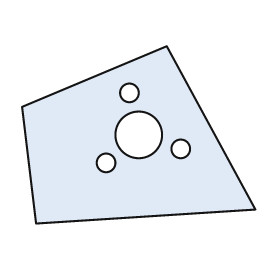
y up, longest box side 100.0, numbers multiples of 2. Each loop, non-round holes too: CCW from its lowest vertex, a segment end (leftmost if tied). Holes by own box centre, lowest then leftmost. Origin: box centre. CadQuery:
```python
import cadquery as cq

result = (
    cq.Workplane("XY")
    .moveTo(-44.0, -38.0)
    .lineTo(50.0, -32.0)
    .lineTo(12.0, 38.0)
    .lineTo(-50.0, 12.0)
    .close()
    .moveTo(-14.0, -12.0)
    .circle(4.0)
    .moveTo(18.0, -6.0)
    .circle(4.0)
    .moveTo(0.0, 0.0)
    .circle(10.0)
    .moveTo(-4.0, 18.0)
    .circle(4.0)
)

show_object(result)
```